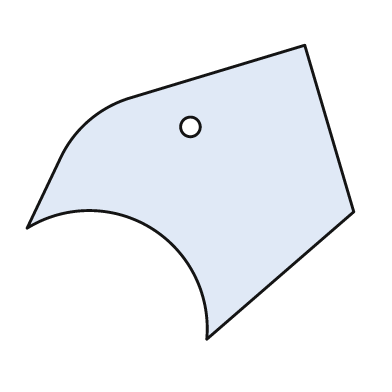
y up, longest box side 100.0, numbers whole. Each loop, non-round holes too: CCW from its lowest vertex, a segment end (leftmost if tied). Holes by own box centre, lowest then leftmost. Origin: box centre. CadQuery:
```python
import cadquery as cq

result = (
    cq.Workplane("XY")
    .moveTo(5.0, -45.0)
    .lineTo(50.0, -6.0)
    .lineTo(35.0, 45.0)
    .lineTo(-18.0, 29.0)
    .threePointArc((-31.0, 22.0), (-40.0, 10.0))
    .lineTo(-50.0, -11.0)
    .threePointArc((-12.0, -11.0), (5.0, -45.0))
    .close()
    .moveTo(0.0, 20.0)
    .circle(3.0)
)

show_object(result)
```